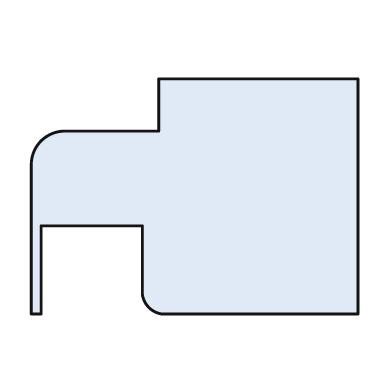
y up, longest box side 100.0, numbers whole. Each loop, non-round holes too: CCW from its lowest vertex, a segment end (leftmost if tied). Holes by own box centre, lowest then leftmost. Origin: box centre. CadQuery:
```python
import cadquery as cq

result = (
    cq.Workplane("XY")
    .moveTo(-50.0, -36.0)
    .lineTo(-47.0, -36.0)
    .lineTo(-47.0, -9.0)
    .lineTo(-16.0, -9.0)
    .lineTo(-16.0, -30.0)
    .threePointArc((-14.0, -34.0), (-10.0, -36.0))
    .lineTo(50.0, -36.0)
    .lineTo(50.0, 36.0)
    .lineTo(-11.0, 36.0)
    .lineTo(-11.0, 20.0)
    .lineTo(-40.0, 20.0)
    .threePointArc((-47.0, 17.0), (-50.0, 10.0))
    .close()
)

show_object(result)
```